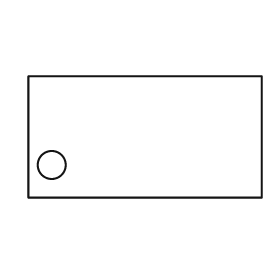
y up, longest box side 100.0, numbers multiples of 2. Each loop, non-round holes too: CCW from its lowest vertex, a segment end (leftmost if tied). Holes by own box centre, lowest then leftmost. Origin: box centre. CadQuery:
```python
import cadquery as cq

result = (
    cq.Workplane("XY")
    .moveTo(-50.0, -26.0)
    .lineTo(50.0, -26.0)
    .lineTo(50.0, 26.0)
    .lineTo(-50.0, 26.0)
    .close()
    .moveTo(-40.0, -12.0)
    .circle(6.0)
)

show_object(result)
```